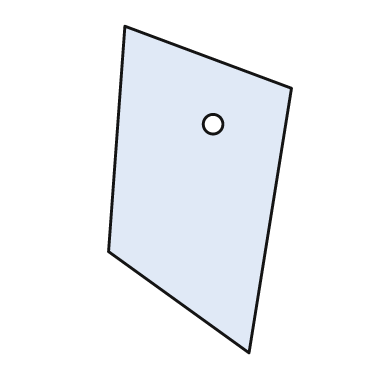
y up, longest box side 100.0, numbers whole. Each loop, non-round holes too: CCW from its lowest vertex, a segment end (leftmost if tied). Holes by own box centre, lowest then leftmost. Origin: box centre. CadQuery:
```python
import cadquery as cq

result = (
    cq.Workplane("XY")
    .moveTo(15.0, -50.0)
    .lineTo(28.0, 31.0)
    .lineTo(-23.0, 50.0)
    .lineTo(-28.0, -19.0)
    .close()
    .moveTo(4.0, 20.0)
    .circle(3.0)
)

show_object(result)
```